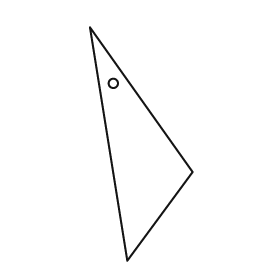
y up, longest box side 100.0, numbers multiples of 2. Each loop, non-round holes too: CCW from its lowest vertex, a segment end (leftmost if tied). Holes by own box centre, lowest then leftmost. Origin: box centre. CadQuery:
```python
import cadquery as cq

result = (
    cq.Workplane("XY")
    .moveTo(-6.0, -50.0)
    .lineTo(22.0, -12.0)
    .lineTo(-22.0, 50.0)
    .close()
    .moveTo(-12.0, 26.0)
    .circle(2.0)
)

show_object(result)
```